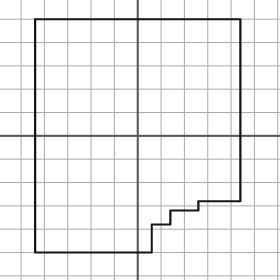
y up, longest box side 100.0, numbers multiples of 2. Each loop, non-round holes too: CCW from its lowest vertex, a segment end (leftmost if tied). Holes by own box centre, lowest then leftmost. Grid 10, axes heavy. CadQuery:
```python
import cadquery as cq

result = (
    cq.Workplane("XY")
    .moveTo(-44.0, -50.0)
    .lineTo(6.0, -50.0)
    .lineTo(6.0, -38.0)
    .lineTo(14.0, -38.0)
    .lineTo(14.0, -32.0)
    .lineTo(26.0, -32.0)
    .lineTo(26.0, -28.0)
    .lineTo(44.0, -28.0)
    .lineTo(44.0, 50.0)
    .lineTo(-44.0, 50.0)
    .close()
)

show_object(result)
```